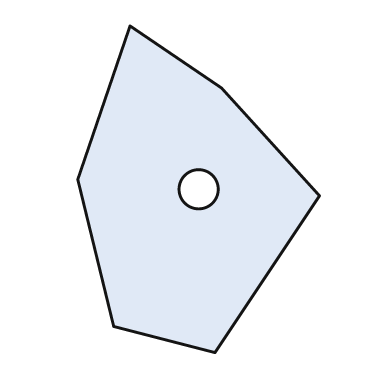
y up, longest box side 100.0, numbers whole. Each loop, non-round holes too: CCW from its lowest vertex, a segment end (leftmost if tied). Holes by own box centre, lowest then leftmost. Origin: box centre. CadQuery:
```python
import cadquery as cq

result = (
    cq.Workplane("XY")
    .moveTo(5.0, -50.0)
    .lineTo(37.0, -2.0)
    .lineTo(7.0, 31.0)
    .lineTo(-21.0, 50.0)
    .lineTo(-37.0, 3.0)
    .lineTo(-26.0, -42.0)
    .close()
    .moveTo(0.0, 0.0)
    .circle(6.0)
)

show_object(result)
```